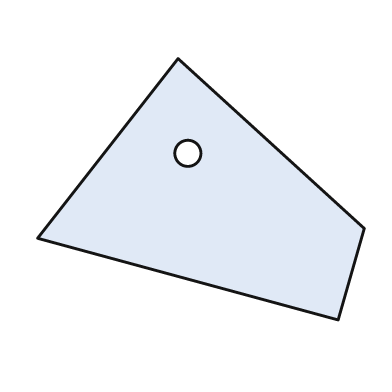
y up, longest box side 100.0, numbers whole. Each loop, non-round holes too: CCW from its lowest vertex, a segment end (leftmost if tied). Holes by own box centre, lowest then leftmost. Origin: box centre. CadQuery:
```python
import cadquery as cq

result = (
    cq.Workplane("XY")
    .moveTo(42.0, -40.0)
    .lineTo(50.0, -12.0)
    .lineTo(-7.0, 40.0)
    .lineTo(-50.0, -15.0)
    .close()
    .moveTo(-4.0, 11.0)
    .circle(4.0)
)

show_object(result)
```